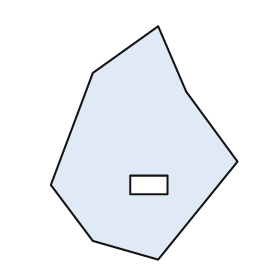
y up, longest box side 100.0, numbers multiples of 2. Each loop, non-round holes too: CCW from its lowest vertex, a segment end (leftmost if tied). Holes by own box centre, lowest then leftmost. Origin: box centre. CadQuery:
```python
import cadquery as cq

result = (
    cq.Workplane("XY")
    .moveTo(6.0, -50.0)
    .lineTo(40.0, -8.0)
    .lineTo(18.0, 22.0)
    .lineTo(6.0, 50.0)
    .lineTo(-22.0, 30.0)
    .lineTo(-40.0, -18.0)
    .lineTo(-22.0, -42.0)
    .close()
    .moveTo(-6.0, -22.0)
    .lineTo(10.0, -22.0)
    .lineTo(10.0, -14.0)
    .lineTo(-6.0, -14.0)
    .close()
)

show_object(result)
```